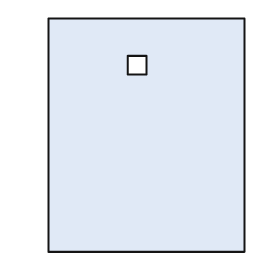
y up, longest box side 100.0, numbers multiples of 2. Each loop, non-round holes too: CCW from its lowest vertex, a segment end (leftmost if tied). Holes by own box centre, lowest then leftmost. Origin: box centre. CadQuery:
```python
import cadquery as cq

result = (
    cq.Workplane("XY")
    .moveTo(-42.0, -50.0)
    .lineTo(42.0, -50.0)
    .lineTo(42.0, 50.0)
    .lineTo(-42.0, 50.0)
    .close()
    .moveTo(-8.0, 26.0)
    .lineTo(0.0, 26.0)
    .lineTo(0.0, 34.0)
    .lineTo(-8.0, 34.0)
    .close()
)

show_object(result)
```